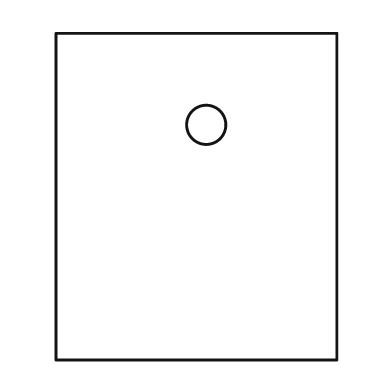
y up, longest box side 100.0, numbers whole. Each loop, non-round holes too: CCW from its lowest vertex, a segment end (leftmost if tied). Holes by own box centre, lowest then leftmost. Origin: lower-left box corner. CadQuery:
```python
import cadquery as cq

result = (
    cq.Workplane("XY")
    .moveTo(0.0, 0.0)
    .lineTo(86.0, 0.0)
    .lineTo(86.0, 100.0)
    .lineTo(0.0, 100.0)
    .close()
    .moveTo(46.0, 72.0)
    .circle(6.0)
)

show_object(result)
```